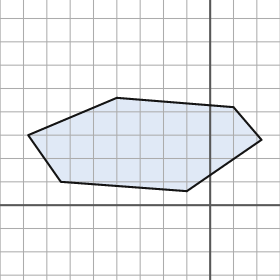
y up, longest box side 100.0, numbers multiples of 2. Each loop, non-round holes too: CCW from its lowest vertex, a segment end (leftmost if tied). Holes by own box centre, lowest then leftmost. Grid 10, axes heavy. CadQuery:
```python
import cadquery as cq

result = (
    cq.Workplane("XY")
    .moveTo(-10.0, 6.0)
    .lineTo(22.0, 28.0)
    .lineTo(10.0, 42.0)
    .lineTo(-40.0, 46.0)
    .lineTo(-78.0, 30.0)
    .lineTo(-64.0, 10.0)
    .close()
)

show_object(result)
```